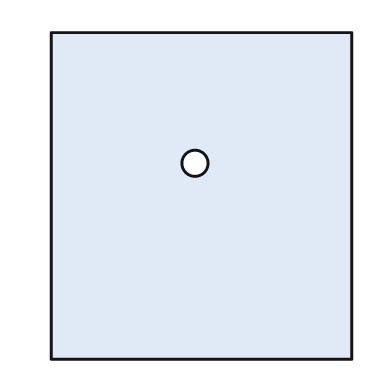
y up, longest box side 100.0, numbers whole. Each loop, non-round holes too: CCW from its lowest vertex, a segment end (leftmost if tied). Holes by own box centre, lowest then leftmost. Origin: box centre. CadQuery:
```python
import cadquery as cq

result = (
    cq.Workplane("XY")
    .moveTo(-46.0, -50.0)
    .lineTo(46.0, -50.0)
    .lineTo(46.0, 50.0)
    .lineTo(-46.0, 50.0)
    .close()
    .moveTo(-2.0, 10.0)
    .circle(4.0)
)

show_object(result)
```